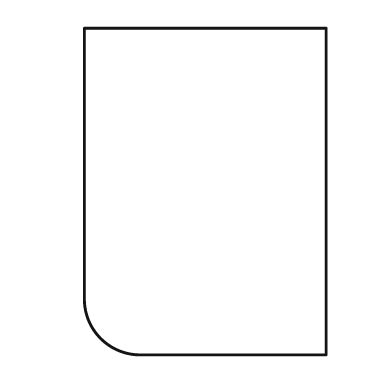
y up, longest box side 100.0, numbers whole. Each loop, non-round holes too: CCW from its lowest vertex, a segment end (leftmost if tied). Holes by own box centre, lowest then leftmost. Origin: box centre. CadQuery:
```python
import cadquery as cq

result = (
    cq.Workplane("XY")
    .moveTo(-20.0, -50.0)
    .lineTo(37.0, -50.0)
    .lineTo(37.0, 50.0)
    .lineTo(-37.0, 50.0)
    .lineTo(-37.0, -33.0)
    .threePointArc((-32.0, -45.0), (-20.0, -50.0))
    .close()
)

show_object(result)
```